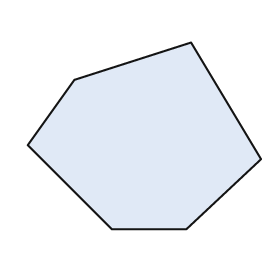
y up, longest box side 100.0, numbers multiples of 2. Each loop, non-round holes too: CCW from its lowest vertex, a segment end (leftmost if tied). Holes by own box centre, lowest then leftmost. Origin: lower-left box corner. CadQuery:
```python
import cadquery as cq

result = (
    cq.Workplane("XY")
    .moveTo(36.0, 0.0)
    .lineTo(68.0, 0.0)
    .lineTo(100.0, 30.0)
    .lineTo(70.0, 80.0)
    .lineTo(20.0, 64.0)
    .lineTo(0.0, 36.0)
    .close()
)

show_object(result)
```